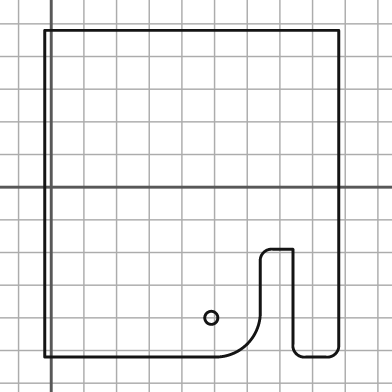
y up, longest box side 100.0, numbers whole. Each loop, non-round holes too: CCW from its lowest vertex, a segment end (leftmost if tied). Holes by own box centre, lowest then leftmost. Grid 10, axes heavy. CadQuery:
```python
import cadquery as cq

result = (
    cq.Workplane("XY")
    .moveTo(-2.0, -52.0)
    .lineTo(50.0, -52.0)
    .threePointArc((60.0, -48.0), (64.0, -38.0))
    .lineTo(64.0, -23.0)
    .threePointArc((65.0, -20.0), (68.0, -19.0))
    .lineTo(74.0, -19.0)
    .lineTo(74.0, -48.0)
    .threePointArc((75.0, -51.0), (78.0, -52.0))
    .lineTo(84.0, -52.0)
    .threePointArc((87.0, -51.0), (88.0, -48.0))
    .lineTo(88.0, 48.0)
    .lineTo(-2.0, 48.0)
    .close()
    .moveTo(49.0, -40.0)
    .circle(2.0)
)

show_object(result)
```